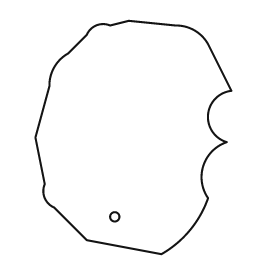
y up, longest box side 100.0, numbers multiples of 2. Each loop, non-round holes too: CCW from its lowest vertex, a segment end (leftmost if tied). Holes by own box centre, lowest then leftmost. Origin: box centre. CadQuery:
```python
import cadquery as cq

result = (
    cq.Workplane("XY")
    .moveTo(12.0, -50.0)
    .threePointArc((24.0, -40.0), (32.0, -26.0))
    .threePointArc((30.0, -12.0), (40.0, -2.0))
    .threePointArc((32.0, 10.0), (42.0, 20.0))
    .lineTo(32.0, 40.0)
    .threePointArc((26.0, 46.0), (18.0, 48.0))
    .lineTo(-2.0, 50.0)
    .lineTo(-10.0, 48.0)
    .threePointArc((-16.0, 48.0), (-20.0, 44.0))
    .lineTo(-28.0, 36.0)
    .threePointArc((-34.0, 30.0), (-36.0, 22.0))
    .lineTo(-42.0, 0.0)
    .lineTo(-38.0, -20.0)
    .threePointArc((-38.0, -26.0), (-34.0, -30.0))
    .lineTo(-20.0, -44.0)
    .close()
    .moveTo(-8.0, -34.0)
    .circle(2.0)
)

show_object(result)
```